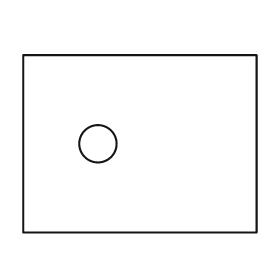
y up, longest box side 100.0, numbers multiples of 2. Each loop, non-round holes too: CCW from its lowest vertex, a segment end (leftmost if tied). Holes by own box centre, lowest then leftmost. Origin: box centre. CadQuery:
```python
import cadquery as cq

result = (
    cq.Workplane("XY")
    .moveTo(-50.0, -38.0)
    .lineTo(50.0, -38.0)
    .lineTo(50.0, 38.0)
    .lineTo(-50.0, 38.0)
    .close()
    .moveTo(-18.0, 0.0)
    .circle(8.0)
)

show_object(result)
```